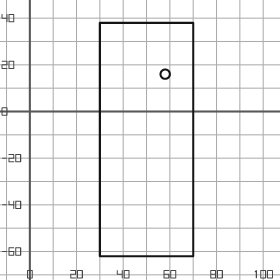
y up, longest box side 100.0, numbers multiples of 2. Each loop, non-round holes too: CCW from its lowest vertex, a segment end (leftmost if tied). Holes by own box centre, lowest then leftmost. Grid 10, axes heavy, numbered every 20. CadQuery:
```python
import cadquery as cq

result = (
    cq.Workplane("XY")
    .moveTo(30.0, -62.0)
    .lineTo(70.0, -62.0)
    .lineTo(70.0, 38.0)
    .lineTo(30.0, 38.0)
    .close()
    .moveTo(58.0, 16.0)
    .circle(2.0)
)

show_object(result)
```